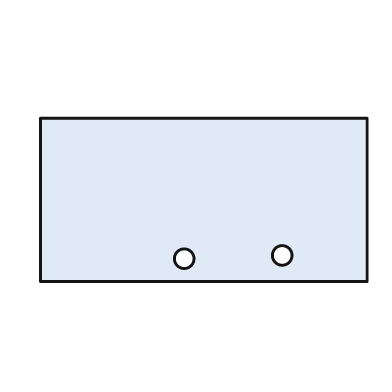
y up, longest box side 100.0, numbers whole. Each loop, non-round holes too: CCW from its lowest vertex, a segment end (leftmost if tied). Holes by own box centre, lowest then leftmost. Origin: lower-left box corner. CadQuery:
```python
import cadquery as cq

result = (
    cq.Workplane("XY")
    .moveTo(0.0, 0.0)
    .lineTo(100.0, 0.0)
    .lineTo(100.0, 50.0)
    .lineTo(0.0, 50.0)
    .close()
    .moveTo(44.0, 7.0)
    .circle(3.0)
    .moveTo(74.0, 8.0)
    .circle(3.0)
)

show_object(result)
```